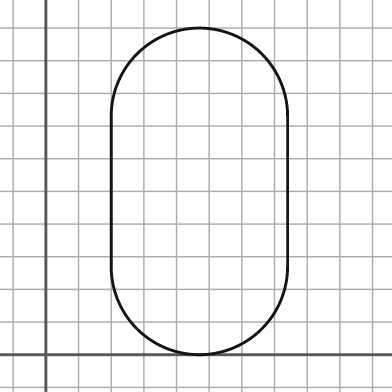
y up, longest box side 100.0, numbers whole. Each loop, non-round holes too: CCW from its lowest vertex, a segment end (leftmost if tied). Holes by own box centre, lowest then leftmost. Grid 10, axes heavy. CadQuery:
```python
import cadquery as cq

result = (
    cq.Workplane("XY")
    .moveTo(20.0, 27.0)
    .threePointArc((47.0, 0.0), (74.0, 27.0))
    .lineTo(74.0, 73.0)
    .threePointArc((47.0, 100.0), (20.0, 73.0))
    .close()
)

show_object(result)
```